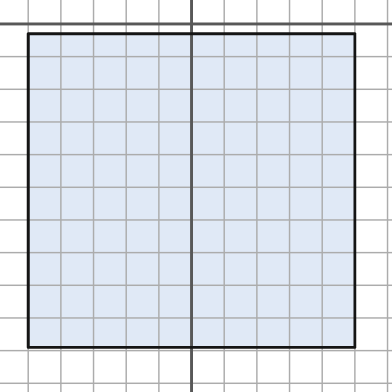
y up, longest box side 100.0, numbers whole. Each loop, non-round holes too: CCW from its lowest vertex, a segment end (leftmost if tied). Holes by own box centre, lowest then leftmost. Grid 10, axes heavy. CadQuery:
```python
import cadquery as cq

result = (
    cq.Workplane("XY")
    .moveTo(-50.0, -99.0)
    .lineTo(50.0, -99.0)
    .lineTo(50.0, -3.0)
    .lineTo(-50.0, -3.0)
    .close()
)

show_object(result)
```